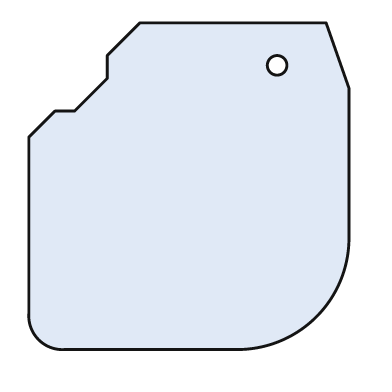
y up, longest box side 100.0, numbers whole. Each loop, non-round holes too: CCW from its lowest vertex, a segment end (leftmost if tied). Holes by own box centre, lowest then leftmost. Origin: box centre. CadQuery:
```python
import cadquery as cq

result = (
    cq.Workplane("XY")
    .moveTo(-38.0, -50.0)
    .lineTo(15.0, -50.0)
    .threePointArc((39.0, -40.0), (49.0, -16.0))
    .lineTo(49.0, 30.0)
    .lineTo(42.0, 50.0)
    .lineTo(-15.0, 50.0)
    .lineTo(-25.0, 40.0)
    .lineTo(-25.0, 33.0)
    .lineTo(-35.0, 23.0)
    .lineTo(-41.0, 23.0)
    .lineTo(-49.0, 15.0)
    .lineTo(-49.0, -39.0)
    .threePointArc((-46.0, -47.0), (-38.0, -50.0))
    .close()
    .moveTo(27.0, 37.0)
    .circle(3.0)
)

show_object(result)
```